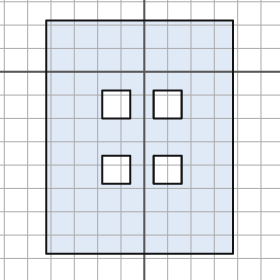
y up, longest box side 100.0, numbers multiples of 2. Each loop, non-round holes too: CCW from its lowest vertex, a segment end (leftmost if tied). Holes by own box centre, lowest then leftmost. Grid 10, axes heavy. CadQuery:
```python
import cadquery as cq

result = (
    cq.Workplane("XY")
    .moveTo(-42.0, -78.0)
    .lineTo(38.0, -78.0)
    .lineTo(38.0, 22.0)
    .lineTo(-42.0, 22.0)
    .close()
    .moveTo(-18.0, -48.0)
    .lineTo(-6.0, -48.0)
    .lineTo(-6.0, -36.0)
    .lineTo(-18.0, -36.0)
    .close()
    .moveTo(4.0, -48.0)
    .lineTo(16.0, -48.0)
    .lineTo(16.0, -36.0)
    .lineTo(4.0, -36.0)
    .close()
    .moveTo(-18.0, -20.0)
    .lineTo(-6.0, -20.0)
    .lineTo(-6.0, -8.0)
    .lineTo(-18.0, -8.0)
    .close()
    .moveTo(4.0, -20.0)
    .lineTo(16.0, -20.0)
    .lineTo(16.0, -8.0)
    .lineTo(4.0, -8.0)
    .close()
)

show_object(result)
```